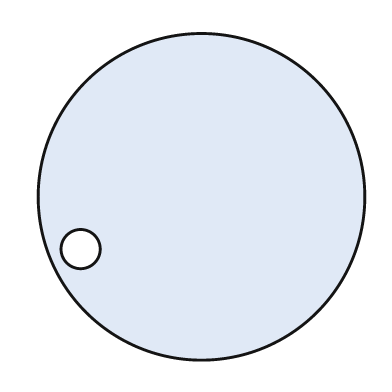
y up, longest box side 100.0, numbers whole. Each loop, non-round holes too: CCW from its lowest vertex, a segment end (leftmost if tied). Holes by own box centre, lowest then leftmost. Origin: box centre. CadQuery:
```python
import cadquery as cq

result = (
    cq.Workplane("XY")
    .moveTo(0.0, 0.0)
    .circle(50.0)
    .moveTo(-37.0, -16.0)
    .circle(6.0)
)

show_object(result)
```